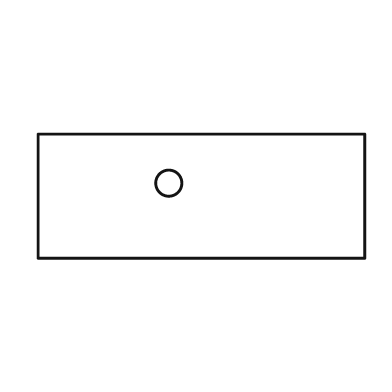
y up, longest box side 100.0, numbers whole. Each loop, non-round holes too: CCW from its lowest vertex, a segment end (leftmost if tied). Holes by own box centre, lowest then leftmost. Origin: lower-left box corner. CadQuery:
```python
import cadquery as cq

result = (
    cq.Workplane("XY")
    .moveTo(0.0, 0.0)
    .lineTo(100.0, 0.0)
    .lineTo(100.0, 38.0)
    .lineTo(0.0, 38.0)
    .close()
    .moveTo(40.0, 23.0)
    .circle(4.0)
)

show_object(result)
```